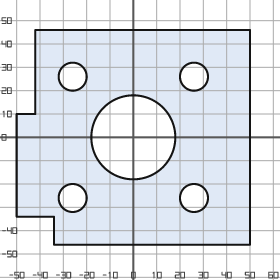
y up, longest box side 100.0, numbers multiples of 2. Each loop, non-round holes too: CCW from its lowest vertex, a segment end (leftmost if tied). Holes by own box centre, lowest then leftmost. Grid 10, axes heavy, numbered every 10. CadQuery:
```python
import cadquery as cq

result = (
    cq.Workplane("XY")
    .moveTo(-34.0, -46.0)
    .lineTo(50.0, -46.0)
    .lineTo(50.0, 46.0)
    .lineTo(-42.0, 46.0)
    .lineTo(-42.0, 10.0)
    .lineTo(-50.0, 10.0)
    .lineTo(-50.0, -34.0)
    .lineTo(-34.0, -34.0)
    .close()
    .moveTo(-26.0, -26.0)
    .circle(6.0)
    .moveTo(26.0, -26.0)
    .circle(6.0)
    .moveTo(0.0, 0.0)
    .circle(18.0)
    .moveTo(-26.0, 26.0)
    .circle(6.0)
    .moveTo(26.0, 26.0)
    .circle(6.0)
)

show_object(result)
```